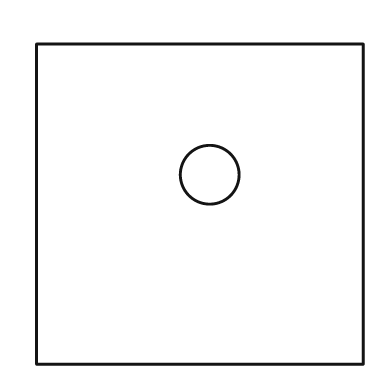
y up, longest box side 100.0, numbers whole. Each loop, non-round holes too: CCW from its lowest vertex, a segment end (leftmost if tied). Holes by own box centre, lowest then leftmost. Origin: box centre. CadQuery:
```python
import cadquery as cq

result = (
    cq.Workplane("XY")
    .moveTo(-50.0, -49.0)
    .lineTo(50.0, -49.0)
    .lineTo(50.0, 49.0)
    .lineTo(-50.0, 49.0)
    .close()
    .moveTo(3.0, 9.0)
    .circle(9.0)
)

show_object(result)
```